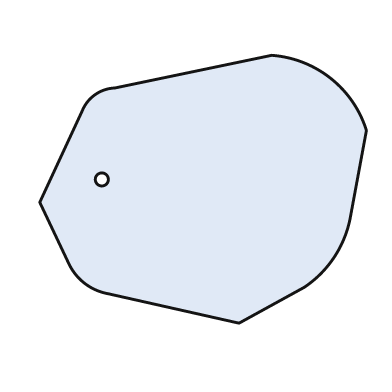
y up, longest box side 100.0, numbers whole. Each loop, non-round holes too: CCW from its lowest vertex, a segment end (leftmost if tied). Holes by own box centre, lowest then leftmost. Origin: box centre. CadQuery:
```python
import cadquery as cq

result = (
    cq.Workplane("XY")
    .moveTo(11.0, -41.0)
    .lineTo(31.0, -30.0)
    .threePointArc((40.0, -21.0), (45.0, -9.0))
    .lineTo(50.0, 18.0)
    .threePointArc((39.0, 34.0), (21.0, 41.0))
    .lineTo(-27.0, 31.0)
    .threePointArc((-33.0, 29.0), (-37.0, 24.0))
    .lineTo(-50.0, -4.0)
    .lineTo(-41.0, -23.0)
    .threePointArc((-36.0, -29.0), (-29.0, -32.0))
    .close()
    .moveTo(-31.0, 3.0)
    .circle(2.0)
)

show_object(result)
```